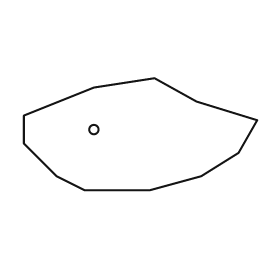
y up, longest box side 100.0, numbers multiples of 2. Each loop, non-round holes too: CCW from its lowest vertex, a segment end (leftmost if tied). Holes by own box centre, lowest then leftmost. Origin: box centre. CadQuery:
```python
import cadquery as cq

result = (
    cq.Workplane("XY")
    .moveTo(-24.0, -24.0)
    .lineTo(4.0, -24.0)
    .lineTo(26.0, -18.0)
    .lineTo(42.0, -8.0)
    .lineTo(50.0, 6.0)
    .lineTo(24.0, 14.0)
    .lineTo(6.0, 24.0)
    .lineTo(-20.0, 20.0)
    .lineTo(-50.0, 8.0)
    .lineTo(-50.0, -4.0)
    .lineTo(-36.0, -18.0)
    .close()
    .moveTo(-20.0, 2.0)
    .circle(2.0)
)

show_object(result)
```